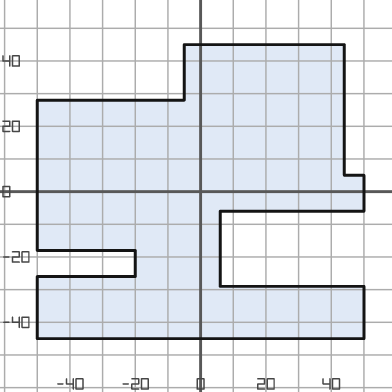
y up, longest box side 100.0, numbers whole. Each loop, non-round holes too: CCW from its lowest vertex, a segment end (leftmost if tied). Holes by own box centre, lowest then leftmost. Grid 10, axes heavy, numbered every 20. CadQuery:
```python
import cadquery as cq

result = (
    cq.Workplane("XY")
    .moveTo(-50.0, -45.0)
    .lineTo(50.0, -45.0)
    .lineTo(50.0, -29.0)
    .lineTo(6.0, -29.0)
    .lineTo(6.0, -6.0)
    .lineTo(50.0, -6.0)
    .lineTo(50.0, 5.0)
    .lineTo(44.0, 5.0)
    .lineTo(44.0, 45.0)
    .lineTo(-5.0, 45.0)
    .lineTo(-5.0, 28.0)
    .lineTo(-50.0, 28.0)
    .lineTo(-50.0, -18.0)
    .lineTo(-20.0, -18.0)
    .lineTo(-20.0, -26.0)
    .lineTo(-50.0, -26.0)
    .close()
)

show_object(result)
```